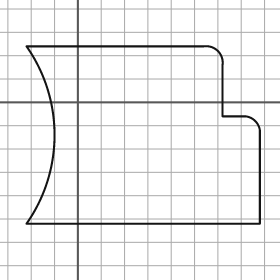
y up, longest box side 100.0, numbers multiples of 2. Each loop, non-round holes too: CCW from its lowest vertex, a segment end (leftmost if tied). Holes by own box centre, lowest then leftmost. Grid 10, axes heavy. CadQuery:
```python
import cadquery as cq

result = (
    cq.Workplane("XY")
    .moveTo(-22.0, -52.0)
    .lineTo(78.0, -52.0)
    .lineTo(78.0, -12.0)
    .threePointArc((76.0, -8.0), (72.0, -6.0))
    .lineTo(62.0, -6.0)
    .lineTo(62.0, 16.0)
    .threePointArc((60.0, 22.0), (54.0, 24.0))
    .lineTo(-22.0, 24.0)
    .threePointArc((-10.0, -14.0), (-22.0, -52.0))
    .close()
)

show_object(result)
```